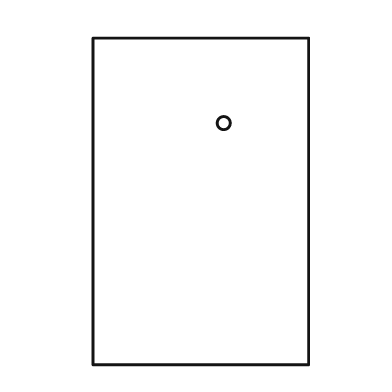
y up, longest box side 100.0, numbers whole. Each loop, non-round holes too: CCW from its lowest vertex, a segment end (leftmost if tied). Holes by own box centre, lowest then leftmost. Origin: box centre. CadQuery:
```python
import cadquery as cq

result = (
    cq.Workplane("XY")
    .moveTo(-33.0, -50.0)
    .lineTo(33.0, -50.0)
    .lineTo(33.0, 50.0)
    .lineTo(-33.0, 50.0)
    .close()
    .moveTo(7.0, 24.0)
    .circle(2.0)
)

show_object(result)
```